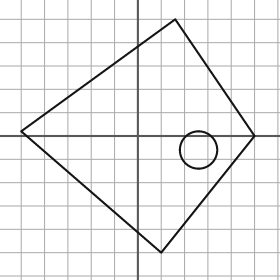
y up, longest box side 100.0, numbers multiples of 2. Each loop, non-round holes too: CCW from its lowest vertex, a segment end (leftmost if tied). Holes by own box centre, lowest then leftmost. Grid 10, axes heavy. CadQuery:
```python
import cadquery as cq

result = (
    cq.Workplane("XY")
    .moveTo(10.0, -50.0)
    .lineTo(50.0, 0.0)
    .lineTo(16.0, 50.0)
    .lineTo(-50.0, 2.0)
    .close()
    .moveTo(26.0, -6.0)
    .circle(8.0)
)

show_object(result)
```